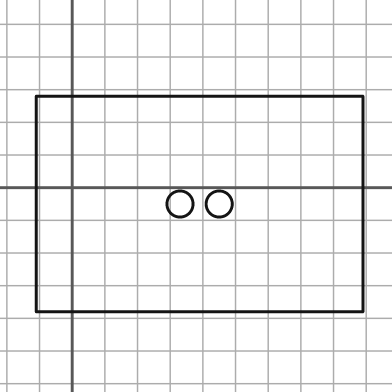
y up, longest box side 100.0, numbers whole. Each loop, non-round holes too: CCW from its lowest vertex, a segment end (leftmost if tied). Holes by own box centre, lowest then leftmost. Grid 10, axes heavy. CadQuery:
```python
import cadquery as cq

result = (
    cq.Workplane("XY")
    .moveTo(-11.0, -38.0)
    .lineTo(89.0, -38.0)
    .lineTo(89.0, 28.0)
    .lineTo(-11.0, 28.0)
    .close()
    .moveTo(33.0, -5.0)
    .circle(4.0)
    .moveTo(45.0, -5.0)
    .circle(4.0)
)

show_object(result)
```